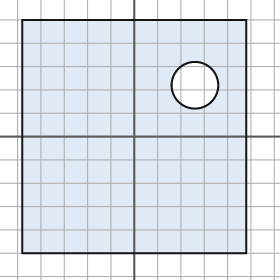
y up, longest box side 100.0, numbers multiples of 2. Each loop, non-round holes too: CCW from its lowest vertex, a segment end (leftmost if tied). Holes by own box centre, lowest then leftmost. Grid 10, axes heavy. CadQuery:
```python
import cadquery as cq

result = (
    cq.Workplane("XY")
    .moveTo(-48.0, -50.0)
    .lineTo(48.0, -50.0)
    .lineTo(48.0, 50.0)
    .lineTo(-48.0, 50.0)
    .close()
    .moveTo(26.0, 22.0)
    .circle(10.0)
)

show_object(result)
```